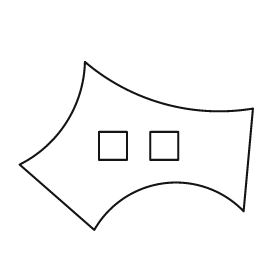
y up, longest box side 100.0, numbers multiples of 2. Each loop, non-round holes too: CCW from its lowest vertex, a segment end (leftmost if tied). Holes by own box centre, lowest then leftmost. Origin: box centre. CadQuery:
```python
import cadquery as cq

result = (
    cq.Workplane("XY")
    .moveTo(-18.0, -36.0)
    .threePointArc((12.0, -16.0), (46.0, -28.0))
    .lineTo(50.0, 16.0)
    .threePointArc((12.0, 18.0), (-22.0, 36.0))
    .threePointArc((-30.0, 10.0), (-50.0, -8.0))
    .close()
    .moveTo(-16.0, -6.0)
    .lineTo(-4.0, -6.0)
    .lineTo(-4.0, 6.0)
    .lineTo(-16.0, 6.0)
    .close()
    .moveTo(6.0, -6.0)
    .lineTo(18.0, -6.0)
    .lineTo(18.0, 6.0)
    .lineTo(6.0, 6.0)
    .close()
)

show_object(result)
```